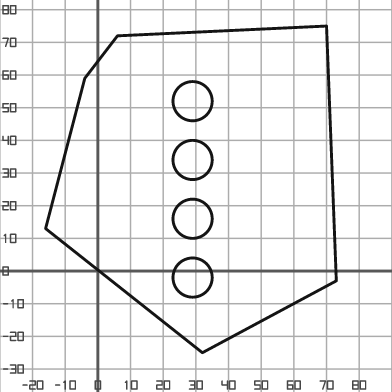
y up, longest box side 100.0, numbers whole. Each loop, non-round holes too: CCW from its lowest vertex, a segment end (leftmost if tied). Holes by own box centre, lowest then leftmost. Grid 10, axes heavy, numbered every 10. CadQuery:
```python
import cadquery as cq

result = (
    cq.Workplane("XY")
    .moveTo(32.0, -25.0)
    .lineTo(73.0, -3.0)
    .lineTo(70.0, 75.0)
    .lineTo(6.0, 72.0)
    .lineTo(-4.0, 59.0)
    .lineTo(-16.0, 13.0)
    .close()
    .moveTo(29.0, -2.0)
    .circle(6.0)
    .moveTo(29.0, 16.0)
    .circle(6.0)
    .moveTo(29.0, 34.0)
    .circle(6.0)
    .moveTo(29.0, 52.0)
    .circle(6.0)
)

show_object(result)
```